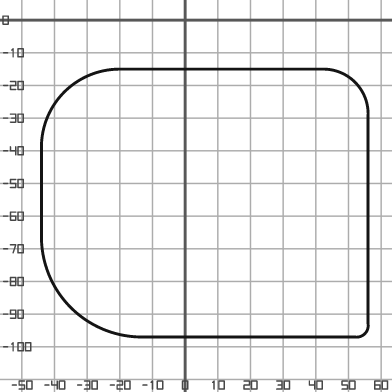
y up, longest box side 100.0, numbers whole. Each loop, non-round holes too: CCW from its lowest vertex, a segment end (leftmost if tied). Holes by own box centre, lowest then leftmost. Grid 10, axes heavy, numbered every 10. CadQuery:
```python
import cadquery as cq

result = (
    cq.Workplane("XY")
    .moveTo(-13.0, -97.0)
    .lineTo(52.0, -97.0)
    .threePointArc((55.0, -96.0), (56.0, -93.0))
    .lineTo(56.0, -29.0)
    .threePointArc((52.0, -19.0), (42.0, -15.0))
    .lineTo(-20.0, -15.0)
    .threePointArc((-37.0, -22.0), (-44.0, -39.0))
    .lineTo(-44.0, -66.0)
    .threePointArc((-35.0, -88.0), (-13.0, -97.0))
    .close()
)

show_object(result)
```